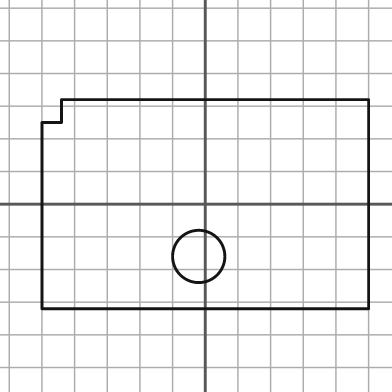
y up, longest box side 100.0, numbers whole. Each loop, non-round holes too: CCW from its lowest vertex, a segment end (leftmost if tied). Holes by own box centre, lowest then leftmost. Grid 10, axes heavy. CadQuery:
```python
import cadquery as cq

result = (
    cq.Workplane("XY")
    .moveTo(-50.0, -32.0)
    .lineTo(50.0, -32.0)
    .lineTo(50.0, 32.0)
    .lineTo(-44.0, 32.0)
    .lineTo(-44.0, 25.0)
    .lineTo(-50.0, 25.0)
    .close()
    .moveTo(-2.0, -16.0)
    .circle(8.0)
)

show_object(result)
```